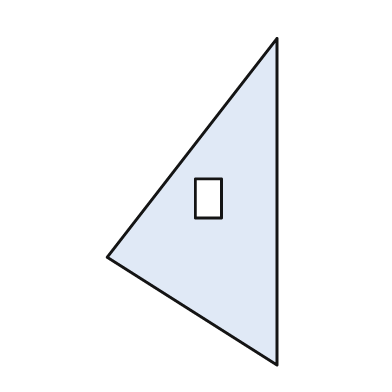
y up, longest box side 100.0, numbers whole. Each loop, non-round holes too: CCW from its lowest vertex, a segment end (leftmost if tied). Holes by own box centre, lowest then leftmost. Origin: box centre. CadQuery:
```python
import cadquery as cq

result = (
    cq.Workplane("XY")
    .moveTo(26.0, -50.0)
    .lineTo(26.0, 50.0)
    .lineTo(-26.0, -17.0)
    .close()
    .moveTo(1.0, -5.0)
    .lineTo(9.0, -5.0)
    .lineTo(9.0, 7.0)
    .lineTo(1.0, 7.0)
    .close()
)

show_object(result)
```